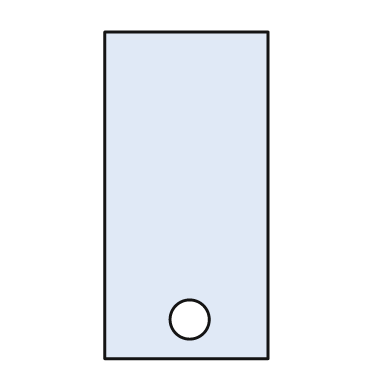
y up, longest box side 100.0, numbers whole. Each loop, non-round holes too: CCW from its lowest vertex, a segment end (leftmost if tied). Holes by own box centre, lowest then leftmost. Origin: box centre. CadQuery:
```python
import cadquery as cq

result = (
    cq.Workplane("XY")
    .moveTo(-25.0, -50.0)
    .lineTo(25.0, -50.0)
    .lineTo(25.0, 50.0)
    .lineTo(-25.0, 50.0)
    .close()
    .moveTo(1.0, -38.0)
    .circle(6.0)
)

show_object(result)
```